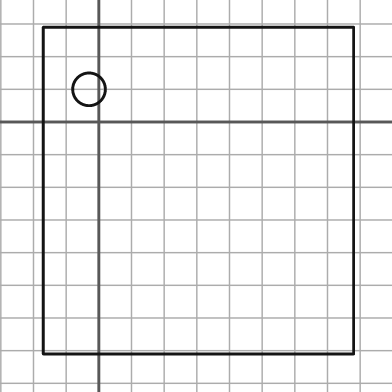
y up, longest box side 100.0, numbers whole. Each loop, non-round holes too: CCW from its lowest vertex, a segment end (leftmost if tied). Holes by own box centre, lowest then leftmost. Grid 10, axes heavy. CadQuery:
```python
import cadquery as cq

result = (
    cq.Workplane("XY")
    .moveTo(-17.0, -71.0)
    .lineTo(78.0, -71.0)
    .lineTo(78.0, 29.0)
    .lineTo(-17.0, 29.0)
    .close()
    .moveTo(-3.0, 10.0)
    .circle(5.0)
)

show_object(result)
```